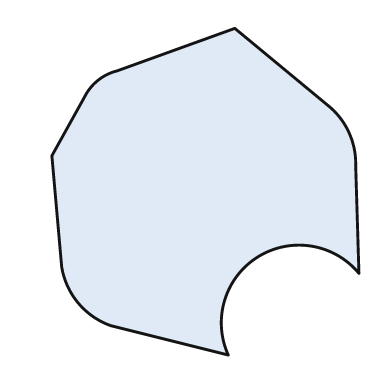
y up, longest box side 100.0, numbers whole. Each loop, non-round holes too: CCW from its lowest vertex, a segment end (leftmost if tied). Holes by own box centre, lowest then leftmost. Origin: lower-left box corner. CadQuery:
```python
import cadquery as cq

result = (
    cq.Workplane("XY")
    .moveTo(54.0, 0.0)
    .threePointArc((63.0, 30.0), (94.0, 25.0))
    .lineTo(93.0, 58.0)
    .threePointArc((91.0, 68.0), (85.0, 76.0))
    .lineTo(56.0, 100.0)
    .lineTo(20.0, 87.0)
    .threePointArc((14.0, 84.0), (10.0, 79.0))
    .lineTo(0.0, 61.0)
    .lineTo(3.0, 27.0)
    .threePointArc((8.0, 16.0), (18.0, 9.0))
    .close()
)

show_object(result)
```